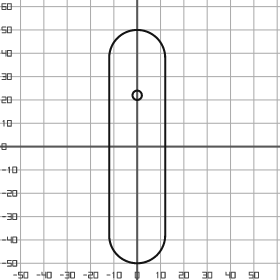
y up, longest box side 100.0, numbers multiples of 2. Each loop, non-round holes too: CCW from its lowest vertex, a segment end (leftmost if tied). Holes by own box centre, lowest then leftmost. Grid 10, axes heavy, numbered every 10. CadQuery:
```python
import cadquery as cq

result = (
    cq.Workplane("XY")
    .moveTo(-12.0, -38.0)
    .threePointArc((0.0, -50.0), (12.0, -38.0))
    .lineTo(12.0, 38.0)
    .threePointArc((0.0, 50.0), (-12.0, 38.0))
    .close()
    .moveTo(0.0, 22.0)
    .circle(2.0)
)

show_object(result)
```